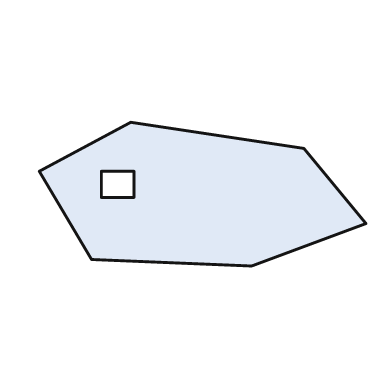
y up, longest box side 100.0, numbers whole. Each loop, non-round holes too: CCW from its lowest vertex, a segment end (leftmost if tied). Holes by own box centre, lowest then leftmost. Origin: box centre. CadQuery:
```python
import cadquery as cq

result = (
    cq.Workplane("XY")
    .moveTo(15.0, -22.0)
    .lineTo(50.0, -9.0)
    .lineTo(31.0, 14.0)
    .lineTo(-22.0, 22.0)
    .lineTo(-50.0, 7.0)
    .lineTo(-34.0, -20.0)
    .close()
    .moveTo(-31.0, -1.0)
    .lineTo(-21.0, -1.0)
    .lineTo(-21.0, 7.0)
    .lineTo(-31.0, 7.0)
    .close()
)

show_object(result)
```